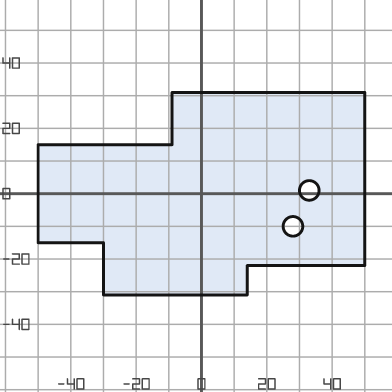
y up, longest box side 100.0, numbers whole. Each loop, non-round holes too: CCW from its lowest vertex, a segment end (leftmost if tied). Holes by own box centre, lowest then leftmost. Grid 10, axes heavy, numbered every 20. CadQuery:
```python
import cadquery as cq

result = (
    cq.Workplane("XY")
    .moveTo(-30.0, -31.0)
    .lineTo(14.0, -31.0)
    .lineTo(14.0, -22.0)
    .lineTo(50.0, -22.0)
    .lineTo(50.0, 31.0)
    .lineTo(-9.0, 31.0)
    .lineTo(-9.0, 15.0)
    .lineTo(-50.0, 15.0)
    .lineTo(-50.0, -15.0)
    .lineTo(-30.0, -15.0)
    .close()
    .moveTo(28.0, -10.0)
    .circle(3.0)
    .moveTo(33.0, 1.0)
    .circle(3.0)
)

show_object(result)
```